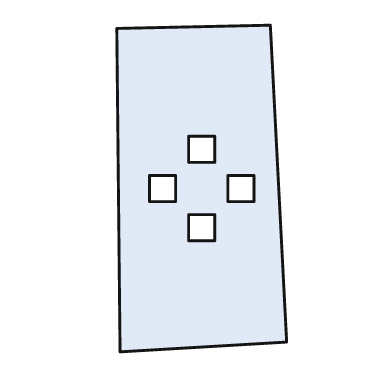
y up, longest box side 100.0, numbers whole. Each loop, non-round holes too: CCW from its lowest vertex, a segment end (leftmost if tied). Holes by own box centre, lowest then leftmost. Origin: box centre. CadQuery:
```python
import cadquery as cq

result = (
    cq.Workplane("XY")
    .moveTo(-25.0, -50.0)
    .lineTo(26.0, -47.0)
    .lineTo(21.0, 50.0)
    .lineTo(-26.0, 49.0)
    .close()
    .moveTo(-4.0, -16.0)
    .lineTo(4.0, -16.0)
    .lineTo(4.0, -8.0)
    .lineTo(-4.0, -8.0)
    .close()
    .moveTo(-16.0, -4.0)
    .lineTo(-8.0, -4.0)
    .lineTo(-8.0, 4.0)
    .lineTo(-16.0, 4.0)
    .close()
    .moveTo(8.0, -4.0)
    .lineTo(16.0, -4.0)
    .lineTo(16.0, 4.0)
    .lineTo(8.0, 4.0)
    .close()
    .moveTo(-4.0, 8.0)
    .lineTo(4.0, 8.0)
    .lineTo(4.0, 16.0)
    .lineTo(-4.0, 16.0)
    .close()
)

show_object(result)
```